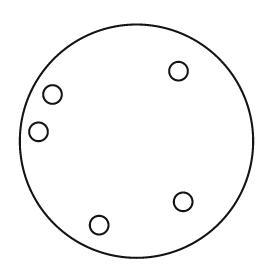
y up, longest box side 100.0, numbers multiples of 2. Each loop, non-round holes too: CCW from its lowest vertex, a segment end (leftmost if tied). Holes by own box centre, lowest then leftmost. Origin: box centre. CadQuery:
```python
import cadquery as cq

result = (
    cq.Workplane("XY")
    .moveTo(0.0, 0.0)
    .circle(50.0)
    .moveTo(-16.0, -36.0)
    .circle(4.0)
    .moveTo(20.0, -26.0)
    .circle(4.0)
    .moveTo(-42.0, 4.0)
    .circle(4.0)
    .moveTo(-36.0, 20.0)
    .circle(4.0)
    .moveTo(18.0, 30.0)
    .circle(4.0)
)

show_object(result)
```